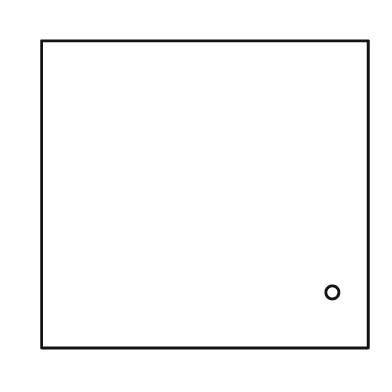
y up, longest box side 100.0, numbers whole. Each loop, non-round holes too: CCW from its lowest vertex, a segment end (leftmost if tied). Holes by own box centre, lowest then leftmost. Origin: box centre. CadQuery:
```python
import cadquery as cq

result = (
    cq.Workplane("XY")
    .moveTo(-50.0, -47.0)
    .lineTo(50.0, -47.0)
    .lineTo(50.0, 47.0)
    .lineTo(-50.0, 47.0)
    .close()
    .moveTo(39.0, -30.0)
    .circle(2.0)
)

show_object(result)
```